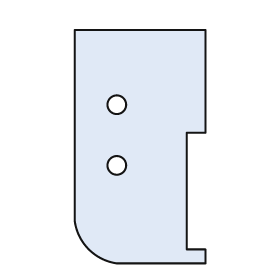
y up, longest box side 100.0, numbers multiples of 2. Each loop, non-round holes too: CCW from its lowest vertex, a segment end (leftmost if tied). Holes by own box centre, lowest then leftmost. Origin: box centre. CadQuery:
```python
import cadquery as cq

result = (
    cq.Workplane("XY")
    .moveTo(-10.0, -50.0)
    .lineTo(28.0, -50.0)
    .lineTo(28.0, -44.0)
    .lineTo(20.0, -44.0)
    .lineTo(20.0, 6.0)
    .lineTo(28.0, 6.0)
    .lineTo(28.0, 50.0)
    .lineTo(-28.0, 50.0)
    .lineTo(-28.0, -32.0)
    .threePointArc((-22.0, -44.0), (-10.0, -50.0))
    .close()
    .moveTo(-10.0, -8.0)
    .circle(4.0)
    .moveTo(-10.0, 18.0)
    .circle(4.0)
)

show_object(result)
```